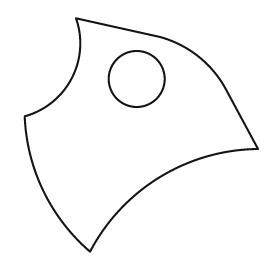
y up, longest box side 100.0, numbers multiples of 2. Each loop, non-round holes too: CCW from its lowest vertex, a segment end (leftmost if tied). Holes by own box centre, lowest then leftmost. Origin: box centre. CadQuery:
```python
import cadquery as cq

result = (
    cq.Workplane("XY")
    .moveTo(-22.0, -50.0)
    .threePointArc((8.0, -18.0), (50.0, -6.0))
    .lineTo(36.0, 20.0)
    .threePointArc((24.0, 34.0), (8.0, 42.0))
    .lineTo(-28.0, 50.0)
    .threePointArc((-30.0, 24.0), (-50.0, 8.0))
    .threePointArc((-42.0, -24.0), (-22.0, -50.0))
    .close()
    .moveTo(-2.0, 24.0)
    .circle(12.0)
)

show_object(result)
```